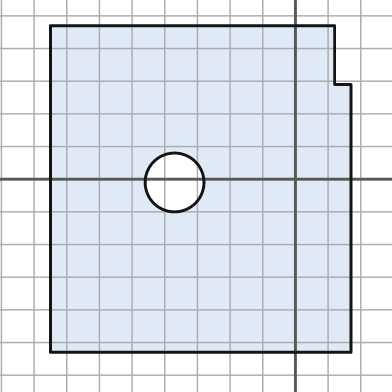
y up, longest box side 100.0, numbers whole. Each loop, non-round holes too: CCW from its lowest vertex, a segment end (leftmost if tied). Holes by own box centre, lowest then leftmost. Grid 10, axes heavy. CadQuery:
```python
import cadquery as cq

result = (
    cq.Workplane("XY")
    .moveTo(-75.0, -53.0)
    .lineTo(17.0, -53.0)
    .lineTo(17.0, 29.0)
    .lineTo(12.0, 29.0)
    .lineTo(12.0, 47.0)
    .lineTo(-75.0, 47.0)
    .close()
    .moveTo(-37.0, -1.0)
    .circle(9.0)
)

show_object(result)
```